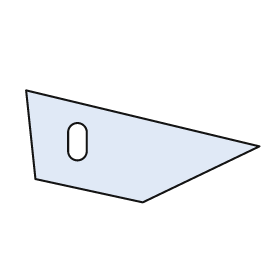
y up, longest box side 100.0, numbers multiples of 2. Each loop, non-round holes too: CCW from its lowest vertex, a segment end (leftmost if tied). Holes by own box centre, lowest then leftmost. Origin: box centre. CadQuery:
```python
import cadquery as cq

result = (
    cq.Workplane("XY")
    .moveTo(0.0, -24.0)
    .lineTo(50.0, 0.0)
    .lineTo(-50.0, 24.0)
    .lineTo(-46.0, -14.0)
    .close()
    .moveTo(-32.0, -2.0)
    .threePointArc((-28.0, -6.0), (-24.0, -2.0))
    .lineTo(-24.0, 6.0)
    .threePointArc((-28.0, 10.0), (-32.0, 6.0))
    .close()
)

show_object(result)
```